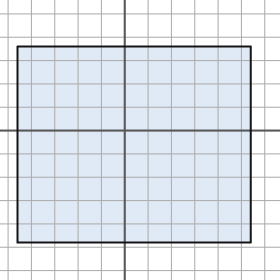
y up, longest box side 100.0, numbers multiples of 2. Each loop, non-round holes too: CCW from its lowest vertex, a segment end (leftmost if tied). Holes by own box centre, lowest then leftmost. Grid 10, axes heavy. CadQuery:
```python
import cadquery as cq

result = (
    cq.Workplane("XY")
    .moveTo(-46.0, -48.0)
    .lineTo(54.0, -48.0)
    .lineTo(54.0, 36.0)
    .lineTo(-46.0, 36.0)
    .close()
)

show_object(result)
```